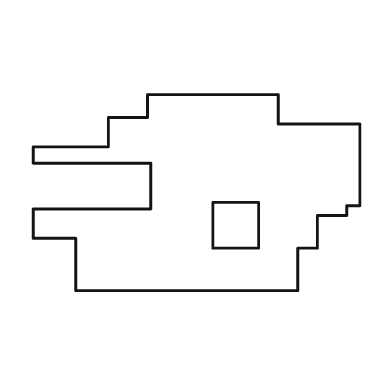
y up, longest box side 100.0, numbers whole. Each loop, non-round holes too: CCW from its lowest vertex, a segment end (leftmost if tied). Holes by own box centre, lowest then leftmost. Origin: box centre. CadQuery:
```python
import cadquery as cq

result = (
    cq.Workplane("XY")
    .moveTo(-37.0, -30.0)
    .lineTo(31.0, -30.0)
    .lineTo(31.0, -17.0)
    .lineTo(37.0, -17.0)
    .lineTo(37.0, -7.0)
    .lineTo(46.0, -7.0)
    .lineTo(46.0, -4.0)
    .lineTo(50.0, -4.0)
    .lineTo(50.0, 21.0)
    .lineTo(25.0, 21.0)
    .lineTo(25.0, 30.0)
    .lineTo(-15.0, 30.0)
    .lineTo(-15.0, 23.0)
    .lineTo(-27.0, 23.0)
    .lineTo(-27.0, 14.0)
    .lineTo(-50.0, 14.0)
    .lineTo(-50.0, 9.0)
    .lineTo(-14.0, 9.0)
    .lineTo(-14.0, -5.0)
    .lineTo(-50.0, -5.0)
    .lineTo(-50.0, -14.0)
    .lineTo(-37.0, -14.0)
    .close()
    .moveTo(5.0, -17.0)
    .lineTo(19.0, -17.0)
    .lineTo(19.0, -3.0)
    .lineTo(5.0, -3.0)
    .close()
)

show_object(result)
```